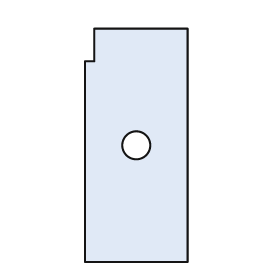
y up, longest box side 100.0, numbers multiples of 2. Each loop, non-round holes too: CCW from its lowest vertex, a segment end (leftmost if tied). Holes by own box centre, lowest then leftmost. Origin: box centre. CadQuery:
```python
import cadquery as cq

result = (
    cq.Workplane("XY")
    .moveTo(-22.0, -50.0)
    .lineTo(22.0, -50.0)
    .lineTo(22.0, 50.0)
    .lineTo(-18.0, 50.0)
    .lineTo(-18.0, 36.0)
    .lineTo(-22.0, 36.0)
    .close()
    .moveTo(0.0, 0.0)
    .circle(6.0)
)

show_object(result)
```